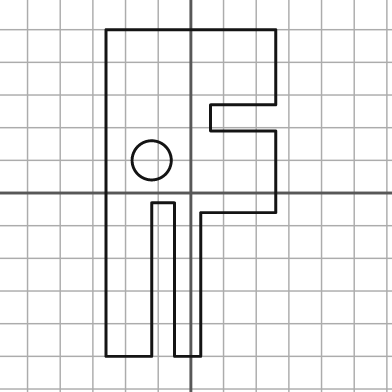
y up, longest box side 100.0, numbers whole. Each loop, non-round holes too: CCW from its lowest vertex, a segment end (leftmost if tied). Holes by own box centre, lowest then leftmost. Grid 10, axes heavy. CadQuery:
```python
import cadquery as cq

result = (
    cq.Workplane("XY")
    .moveTo(-26.0, -50.0)
    .lineTo(-12.0, -50.0)
    .lineTo(-12.0, -3.0)
    .lineTo(-5.0, -3.0)
    .lineTo(-5.0, -50.0)
    .lineTo(3.0, -50.0)
    .lineTo(3.0, -6.0)
    .lineTo(26.0, -6.0)
    .lineTo(26.0, 19.0)
    .lineTo(6.0, 19.0)
    .lineTo(6.0, 27.0)
    .lineTo(26.0, 27.0)
    .lineTo(26.0, 50.0)
    .lineTo(-26.0, 50.0)
    .close()
    .moveTo(-12.0, 10.0)
    .circle(6.0)
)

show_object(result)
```